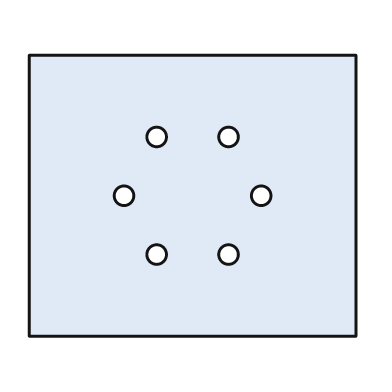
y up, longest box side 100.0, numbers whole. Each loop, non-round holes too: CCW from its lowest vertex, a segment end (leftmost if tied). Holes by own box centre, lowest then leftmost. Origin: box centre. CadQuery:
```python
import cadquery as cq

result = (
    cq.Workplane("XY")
    .moveTo(-50.0, -43.0)
    .lineTo(50.0, -43.0)
    .lineTo(50.0, 43.0)
    .lineTo(-50.0, 43.0)
    .close()
    .moveTo(-11.0, -18.0)
    .circle(3.0)
    .moveTo(11.0, -18.0)
    .circle(3.0)
    .moveTo(-21.0, 0.0)
    .circle(3.0)
    .moveTo(21.0, 0.0)
    .circle(3.0)
    .moveTo(-11.0, 18.0)
    .circle(3.0)
    .moveTo(11.0, 18.0)
    .circle(3.0)
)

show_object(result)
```